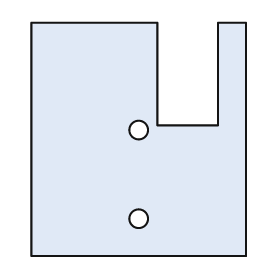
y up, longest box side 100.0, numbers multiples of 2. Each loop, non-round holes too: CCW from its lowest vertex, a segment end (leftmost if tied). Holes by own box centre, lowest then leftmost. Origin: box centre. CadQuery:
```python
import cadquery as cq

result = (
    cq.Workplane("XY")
    .moveTo(-46.0, -50.0)
    .lineTo(46.0, -50.0)
    .lineTo(46.0, 50.0)
    .lineTo(34.0, 50.0)
    .lineTo(34.0, 6.0)
    .lineTo(8.0, 6.0)
    .lineTo(8.0, 50.0)
    .lineTo(-46.0, 50.0)
    .close()
    .moveTo(0.0, -34.0)
    .circle(4.0)
    .moveTo(0.0, 4.0)
    .circle(4.0)
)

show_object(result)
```